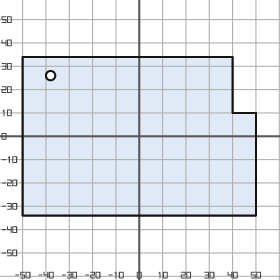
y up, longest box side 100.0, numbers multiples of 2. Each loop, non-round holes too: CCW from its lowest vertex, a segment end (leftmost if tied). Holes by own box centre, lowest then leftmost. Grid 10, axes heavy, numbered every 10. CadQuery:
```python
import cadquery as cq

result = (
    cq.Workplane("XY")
    .moveTo(-50.0, -34.0)
    .lineTo(50.0, -34.0)
    .lineTo(50.0, 10.0)
    .lineTo(40.0, 10.0)
    .lineTo(40.0, 34.0)
    .lineTo(-50.0, 34.0)
    .close()
    .moveTo(-38.0, 26.0)
    .circle(2.0)
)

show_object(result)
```